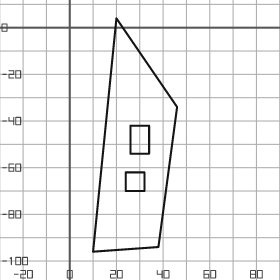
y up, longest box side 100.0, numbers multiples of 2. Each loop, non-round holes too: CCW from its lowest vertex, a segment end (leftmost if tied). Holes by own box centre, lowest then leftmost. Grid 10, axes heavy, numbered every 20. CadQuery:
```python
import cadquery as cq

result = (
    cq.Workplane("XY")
    .moveTo(10.0, -96.0)
    .lineTo(38.0, -94.0)
    .lineTo(46.0, -34.0)
    .lineTo(20.0, 4.0)
    .close()
    .moveTo(24.0, -70.0)
    .lineTo(32.0, -70.0)
    .lineTo(32.0, -62.0)
    .lineTo(24.0, -62.0)
    .close()
    .moveTo(26.0, -54.0)
    .lineTo(34.0, -54.0)
    .lineTo(34.0, -42.0)
    .lineTo(26.0, -42.0)
    .close()
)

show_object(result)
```